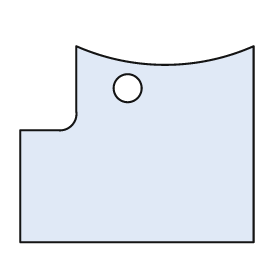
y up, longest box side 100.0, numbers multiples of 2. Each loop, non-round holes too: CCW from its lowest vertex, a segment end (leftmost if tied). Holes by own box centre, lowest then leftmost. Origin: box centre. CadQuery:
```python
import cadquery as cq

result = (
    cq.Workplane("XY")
    .moveTo(-50.0, -42.0)
    .lineTo(50.0, -42.0)
    .lineTo(50.0, 42.0)
    .threePointArc((12.0, 34.0), (-26.0, 42.0))
    .lineTo(-26.0, 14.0)
    .threePointArc((-28.0, 8.0), (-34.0, 6.0))
    .lineTo(-50.0, 6.0)
    .close()
    .moveTo(-4.0, 24.0)
    .circle(6.0)
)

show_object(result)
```